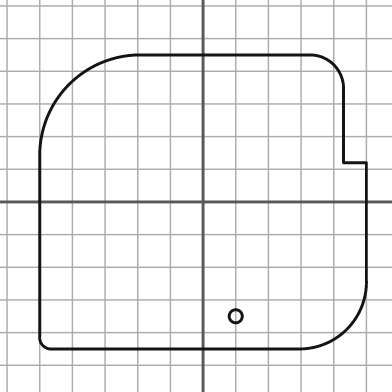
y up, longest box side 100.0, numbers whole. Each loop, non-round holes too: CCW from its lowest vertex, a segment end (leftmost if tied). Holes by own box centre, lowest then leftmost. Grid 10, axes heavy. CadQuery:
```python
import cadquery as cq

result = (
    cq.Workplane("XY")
    .moveTo(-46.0, -45.0)
    .lineTo(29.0, -45.0)
    .threePointArc((44.0, -39.0), (50.0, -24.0))
    .lineTo(50.0, 12.0)
    .lineTo(43.0, 12.0)
    .lineTo(43.0, 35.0)
    .threePointArc((40.0, 42.0), (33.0, 45.0))
    .lineTo(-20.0, 45.0)
    .threePointArc((-41.0, 36.0), (-50.0, 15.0))
    .lineTo(-50.0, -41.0)
    .threePointArc((-49.0, -44.0), (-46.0, -45.0))
    .close()
    .moveTo(10.0, -35.0)
    .circle(2.0)
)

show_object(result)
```